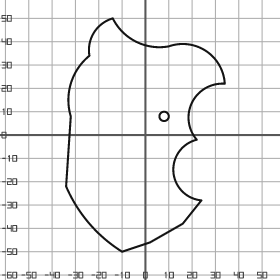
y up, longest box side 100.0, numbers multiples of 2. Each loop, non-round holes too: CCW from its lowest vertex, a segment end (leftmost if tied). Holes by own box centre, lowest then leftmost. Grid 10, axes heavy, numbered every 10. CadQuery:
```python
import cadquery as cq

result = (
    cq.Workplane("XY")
    .moveTo(-10.0, -50.0)
    .lineTo(2.0, -46.0)
    .lineTo(16.0, -38.0)
    .lineTo(24.0, -28.0)
    .threePointArc((12.0, -16.0), (22.0, -2.0))
    .threePointArc((20.0, 14.0), (34.0, 22.0))
    .threePointArc((26.0, 36.0), (10.0, 38.0))
    .threePointArc((-4.0, 40.0), (-14.0, 50.0))
    .threePointArc((-22.0, 44.0), (-24.0, 34.0))
    .threePointArc((-32.0, 22.0), (-32.0, 8.0))
    .lineTo(-34.0, -22.0)
    .threePointArc((-24.0, -38.0), (-10.0, -50.0))
    .close()
    .moveTo(8.0, 8.0)
    .circle(2.0)
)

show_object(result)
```